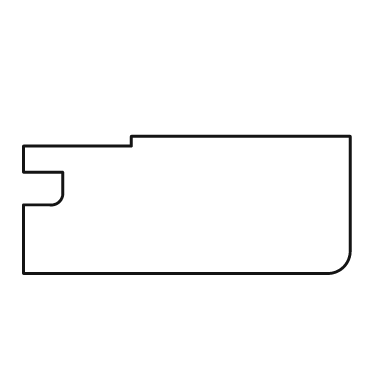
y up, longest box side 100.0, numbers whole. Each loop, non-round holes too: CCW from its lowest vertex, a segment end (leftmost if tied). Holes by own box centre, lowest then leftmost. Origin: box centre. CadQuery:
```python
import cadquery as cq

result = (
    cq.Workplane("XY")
    .moveTo(-50.0, -21.0)
    .lineTo(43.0, -21.0)
    .threePointArc((48.0, -19.0), (50.0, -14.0))
    .lineTo(50.0, 21.0)
    .lineTo(-17.0, 21.0)
    .lineTo(-17.0, 18.0)
    .lineTo(-50.0, 18.0)
    .lineTo(-50.0, 10.0)
    .lineTo(-38.0, 10.0)
    .lineTo(-38.0, 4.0)
    .threePointArc((-39.0, 1.0), (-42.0, 0.0))
    .lineTo(-50.0, 0.0)
    .close()
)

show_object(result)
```